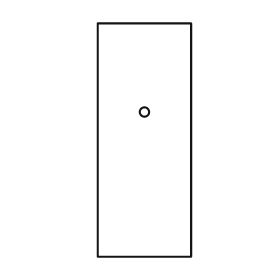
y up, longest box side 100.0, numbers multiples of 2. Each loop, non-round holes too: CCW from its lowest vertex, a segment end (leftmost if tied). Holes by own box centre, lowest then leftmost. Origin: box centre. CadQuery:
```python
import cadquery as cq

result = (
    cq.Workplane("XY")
    .moveTo(-20.0, -50.0)
    .lineTo(20.0, -50.0)
    .lineTo(20.0, 50.0)
    .lineTo(-20.0, 50.0)
    .close()
    .moveTo(0.0, 12.0)
    .circle(2.0)
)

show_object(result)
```